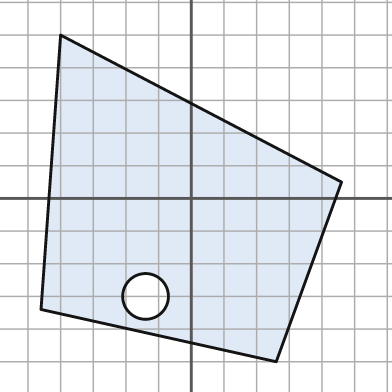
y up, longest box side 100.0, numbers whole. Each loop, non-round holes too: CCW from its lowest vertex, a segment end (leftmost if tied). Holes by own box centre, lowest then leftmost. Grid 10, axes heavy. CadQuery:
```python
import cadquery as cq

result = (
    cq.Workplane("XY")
    .moveTo(26.0, -50.0)
    .lineTo(46.0, 5.0)
    .lineTo(-40.0, 50.0)
    .lineTo(-46.0, -34.0)
    .close()
    .moveTo(-14.0, -30.0)
    .circle(7.0)
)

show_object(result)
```